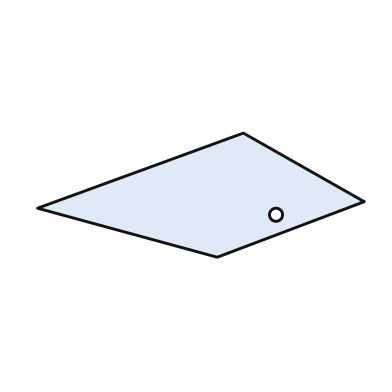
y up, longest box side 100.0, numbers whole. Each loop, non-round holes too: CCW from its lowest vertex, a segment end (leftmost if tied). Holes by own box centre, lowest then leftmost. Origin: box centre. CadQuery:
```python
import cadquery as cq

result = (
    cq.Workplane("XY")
    .moveTo(5.0, -19.0)
    .lineTo(50.0, -2.0)
    .lineTo(13.0, 19.0)
    .lineTo(-50.0, -4.0)
    .close()
    .moveTo(23.0, -6.0)
    .circle(2.0)
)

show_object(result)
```